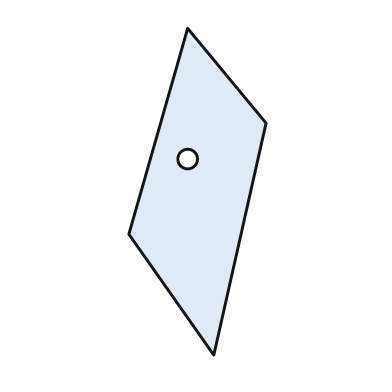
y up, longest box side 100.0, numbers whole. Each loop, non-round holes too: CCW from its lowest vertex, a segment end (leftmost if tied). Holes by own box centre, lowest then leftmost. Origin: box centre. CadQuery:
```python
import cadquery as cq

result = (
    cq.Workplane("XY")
    .moveTo(5.0, -50.0)
    .lineTo(21.0, 21.0)
    .lineTo(-3.0, 50.0)
    .lineTo(-21.0, -13.0)
    .close()
    .moveTo(-3.0, 10.0)
    .circle(3.0)
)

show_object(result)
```